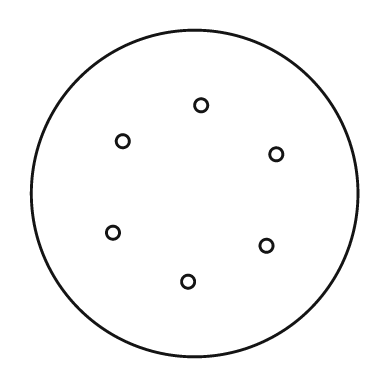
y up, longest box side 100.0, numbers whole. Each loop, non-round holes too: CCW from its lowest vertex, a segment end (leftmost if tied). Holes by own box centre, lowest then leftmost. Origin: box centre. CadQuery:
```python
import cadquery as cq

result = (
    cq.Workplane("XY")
    .moveTo(0.0, 0.0)
    .circle(50.0)
    .moveTo(-2.0, -27.0)
    .circle(2.0)
    .moveTo(22.0, -16.0)
    .circle(2.0)
    .moveTo(-25.0, -12.0)
    .circle(2.0)
    .moveTo(25.0, 12.0)
    .circle(2.0)
    .moveTo(-22.0, 16.0)
    .circle(2.0)
    .moveTo(2.0, 27.0)
    .circle(2.0)
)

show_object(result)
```